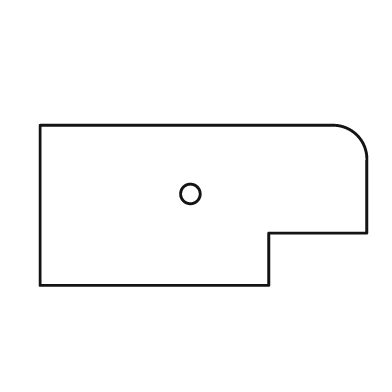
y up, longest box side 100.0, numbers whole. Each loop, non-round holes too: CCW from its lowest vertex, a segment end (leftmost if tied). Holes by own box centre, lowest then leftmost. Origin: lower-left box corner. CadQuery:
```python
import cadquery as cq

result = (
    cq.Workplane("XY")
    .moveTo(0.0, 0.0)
    .lineTo(70.0, 0.0)
    .lineTo(70.0, 16.0)
    .lineTo(100.0, 16.0)
    .lineTo(100.0, 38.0)
    .threePointArc((97.0, 46.0), (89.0, 49.0))
    .lineTo(0.0, 49.0)
    .close()
    .moveTo(46.0, 28.0)
    .circle(3.0)
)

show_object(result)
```